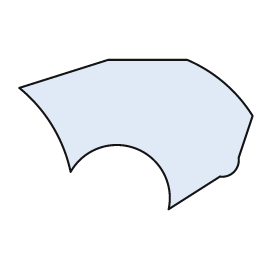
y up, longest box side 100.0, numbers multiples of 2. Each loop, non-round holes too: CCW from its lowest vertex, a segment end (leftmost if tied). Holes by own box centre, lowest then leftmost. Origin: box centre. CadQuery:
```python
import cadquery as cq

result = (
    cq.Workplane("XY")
    .moveTo(14.0, -32.0)
    .lineTo(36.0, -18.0)
    .threePointArc((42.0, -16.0), (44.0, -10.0))
    .lineTo(50.0, 8.0)
    .threePointArc((38.0, 22.0), (22.0, 32.0))
    .lineTo(-12.0, 32.0)
    .lineTo(-50.0, 20.0)
    .threePointArc((-36.0, 4.0), (-28.0, -16.0))
    .threePointArc((0.0, -6.0), (14.0, -32.0))
    .close()
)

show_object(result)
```